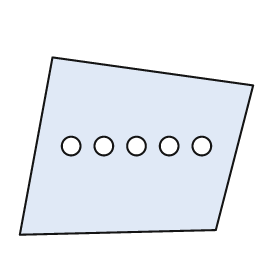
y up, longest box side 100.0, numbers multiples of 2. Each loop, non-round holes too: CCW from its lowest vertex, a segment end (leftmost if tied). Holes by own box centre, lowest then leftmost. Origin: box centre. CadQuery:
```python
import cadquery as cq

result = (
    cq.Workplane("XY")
    .moveTo(-50.0, -38.0)
    .lineTo(34.0, -36.0)
    .lineTo(50.0, 26.0)
    .lineTo(-36.0, 38.0)
    .close()
    .moveTo(-28.0, 0.0)
    .circle(4.0)
    .moveTo(-14.0, 0.0)
    .circle(4.0)
    .moveTo(0.0, 0.0)
    .circle(4.0)
    .moveTo(14.0, 0.0)
    .circle(4.0)
    .moveTo(28.0, 0.0)
    .circle(4.0)
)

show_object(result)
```